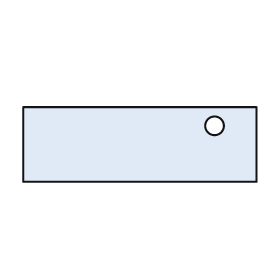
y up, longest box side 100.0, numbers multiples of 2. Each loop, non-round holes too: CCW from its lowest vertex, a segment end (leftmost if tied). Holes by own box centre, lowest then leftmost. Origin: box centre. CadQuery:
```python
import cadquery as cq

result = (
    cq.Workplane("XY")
    .moveTo(-50.0, -16.0)
    .lineTo(50.0, -16.0)
    .lineTo(50.0, 16.0)
    .lineTo(-50.0, 16.0)
    .close()
    .moveTo(32.0, 8.0)
    .circle(4.0)
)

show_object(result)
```